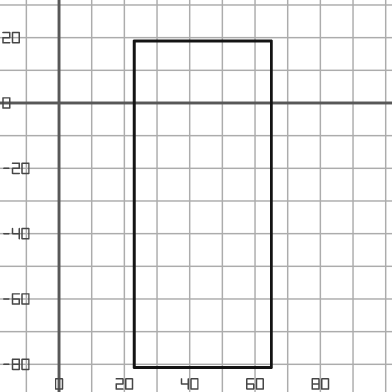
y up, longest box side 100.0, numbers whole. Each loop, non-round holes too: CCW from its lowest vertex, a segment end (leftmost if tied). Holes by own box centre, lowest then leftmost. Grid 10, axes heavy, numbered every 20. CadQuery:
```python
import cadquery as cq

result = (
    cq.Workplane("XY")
    .moveTo(23.0, -81.0)
    .lineTo(65.0, -81.0)
    .lineTo(65.0, 19.0)
    .lineTo(23.0, 19.0)
    .close()
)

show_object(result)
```